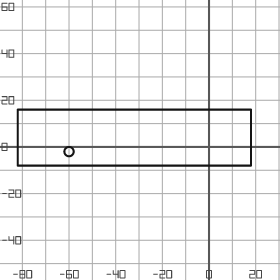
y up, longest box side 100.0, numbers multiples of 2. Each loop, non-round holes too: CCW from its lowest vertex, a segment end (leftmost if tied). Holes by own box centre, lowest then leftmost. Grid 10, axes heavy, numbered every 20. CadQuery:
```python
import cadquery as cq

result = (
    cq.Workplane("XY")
    .moveTo(-82.0, -8.0)
    .lineTo(18.0, -8.0)
    .lineTo(18.0, 16.0)
    .lineTo(-82.0, 16.0)
    .close()
    .moveTo(-60.0, -2.0)
    .circle(2.0)
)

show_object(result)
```